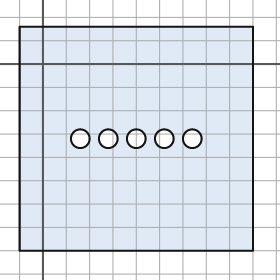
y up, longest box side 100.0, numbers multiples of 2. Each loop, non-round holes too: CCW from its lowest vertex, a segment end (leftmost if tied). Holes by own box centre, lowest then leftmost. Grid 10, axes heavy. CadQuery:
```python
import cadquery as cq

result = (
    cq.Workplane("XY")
    .moveTo(-10.0, -80.0)
    .lineTo(90.0, -80.0)
    .lineTo(90.0, 16.0)
    .lineTo(-10.0, 16.0)
    .close()
    .moveTo(16.0, -32.0)
    .circle(4.0)
    .moveTo(28.0, -32.0)
    .circle(4.0)
    .moveTo(40.0, -32.0)
    .circle(4.0)
    .moveTo(52.0, -32.0)
    .circle(4.0)
    .moveTo(64.0, -32.0)
    .circle(4.0)
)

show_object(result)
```